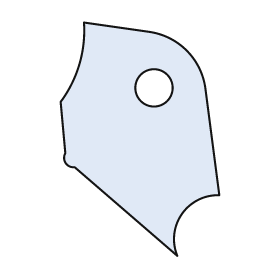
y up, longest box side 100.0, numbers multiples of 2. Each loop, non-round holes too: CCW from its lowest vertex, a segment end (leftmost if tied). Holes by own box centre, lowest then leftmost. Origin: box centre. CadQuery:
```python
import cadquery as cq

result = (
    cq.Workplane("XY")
    .moveTo(16.0, -50.0)
    .threePointArc((18.0, -32.0), (34.0, -24.0))
    .lineTo(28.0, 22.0)
    .threePointArc((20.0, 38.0), (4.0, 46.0))
    .lineTo(-24.0, 50.0)
    .threePointArc((-26.0, 32.0), (-34.0, 16.0))
    .lineTo(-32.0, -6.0)
    .threePointArc((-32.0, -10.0), (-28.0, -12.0))
    .close()
    .moveTo(6.0, 22.0)
    .circle(8.0)
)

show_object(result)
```